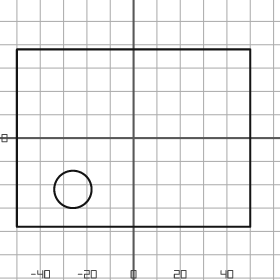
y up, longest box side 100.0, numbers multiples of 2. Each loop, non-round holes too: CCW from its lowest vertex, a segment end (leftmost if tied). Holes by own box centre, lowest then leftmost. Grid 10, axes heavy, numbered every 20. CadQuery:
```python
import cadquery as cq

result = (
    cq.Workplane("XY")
    .moveTo(-50.0, -38.0)
    .lineTo(50.0, -38.0)
    .lineTo(50.0, 38.0)
    .lineTo(-50.0, 38.0)
    .close()
    .moveTo(-26.0, -22.0)
    .circle(8.0)
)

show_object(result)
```